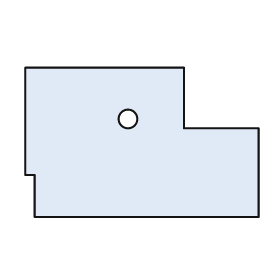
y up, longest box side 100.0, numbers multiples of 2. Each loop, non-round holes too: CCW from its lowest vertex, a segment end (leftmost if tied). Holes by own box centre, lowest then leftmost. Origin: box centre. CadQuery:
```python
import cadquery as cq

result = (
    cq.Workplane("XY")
    .moveTo(-46.0, -32.0)
    .lineTo(50.0, -32.0)
    .lineTo(50.0, 6.0)
    .lineTo(18.0, 6.0)
    .lineTo(18.0, 32.0)
    .lineTo(-50.0, 32.0)
    .lineTo(-50.0, -14.0)
    .lineTo(-46.0, -14.0)
    .close()
    .moveTo(-6.0, 10.0)
    .circle(4.0)
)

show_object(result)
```